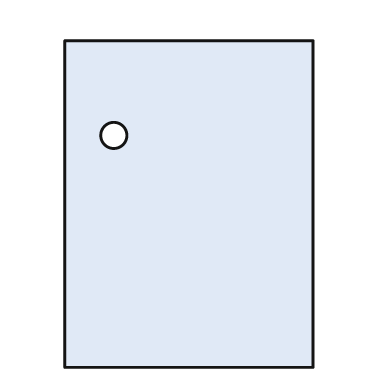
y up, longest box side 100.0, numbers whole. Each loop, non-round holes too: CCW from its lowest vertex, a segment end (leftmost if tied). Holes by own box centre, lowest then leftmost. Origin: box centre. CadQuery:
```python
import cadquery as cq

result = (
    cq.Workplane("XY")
    .moveTo(-38.0, -50.0)
    .lineTo(38.0, -50.0)
    .lineTo(38.0, 50.0)
    .lineTo(-38.0, 50.0)
    .close()
    .moveTo(-23.0, 21.0)
    .circle(4.0)
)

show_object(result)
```